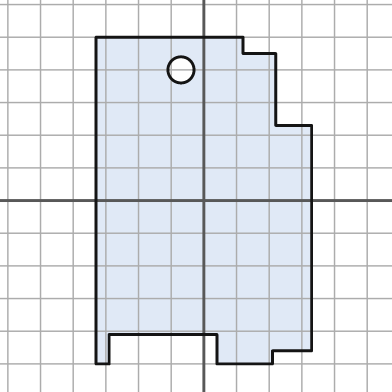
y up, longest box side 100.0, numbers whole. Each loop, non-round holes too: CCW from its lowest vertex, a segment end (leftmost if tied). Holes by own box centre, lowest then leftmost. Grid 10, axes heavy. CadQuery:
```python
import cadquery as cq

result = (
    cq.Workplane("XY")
    .moveTo(-33.0, -50.0)
    .lineTo(-29.0, -50.0)
    .lineTo(-29.0, -41.0)
    .lineTo(4.0, -41.0)
    .lineTo(4.0, -50.0)
    .lineTo(21.0, -50.0)
    .lineTo(21.0, -46.0)
    .lineTo(33.0, -46.0)
    .lineTo(33.0, 23.0)
    .lineTo(22.0, 23.0)
    .lineTo(22.0, 45.0)
    .lineTo(12.0, 45.0)
    .lineTo(12.0, 50.0)
    .lineTo(-33.0, 50.0)
    .close()
    .moveTo(-7.0, 40.0)
    .circle(4.0)
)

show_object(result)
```